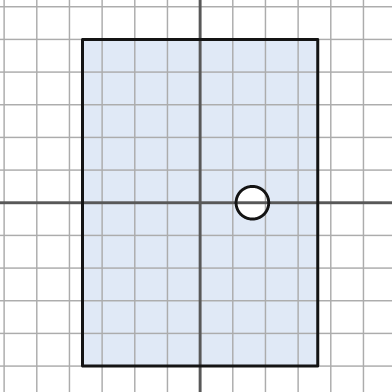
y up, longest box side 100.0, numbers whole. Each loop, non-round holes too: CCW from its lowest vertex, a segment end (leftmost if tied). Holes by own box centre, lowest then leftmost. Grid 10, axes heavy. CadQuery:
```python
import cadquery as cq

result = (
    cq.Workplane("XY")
    .moveTo(-36.0, -50.0)
    .lineTo(36.0, -50.0)
    .lineTo(36.0, 50.0)
    .lineTo(-36.0, 50.0)
    .close()
    .moveTo(16.0, 0.0)
    .circle(5.0)
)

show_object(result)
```